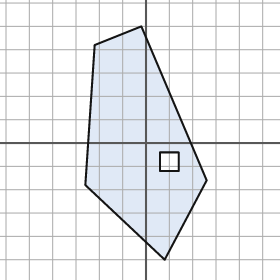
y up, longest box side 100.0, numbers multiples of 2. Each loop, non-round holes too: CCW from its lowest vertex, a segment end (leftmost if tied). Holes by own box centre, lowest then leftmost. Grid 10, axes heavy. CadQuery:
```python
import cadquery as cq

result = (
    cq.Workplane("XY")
    .moveTo(8.0, -50.0)
    .lineTo(26.0, -16.0)
    .lineTo(-2.0, 50.0)
    .lineTo(-22.0, 42.0)
    .lineTo(-26.0, -18.0)
    .close()
    .moveTo(6.0, -12.0)
    .lineTo(14.0, -12.0)
    .lineTo(14.0, -4.0)
    .lineTo(6.0, -4.0)
    .close()
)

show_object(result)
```